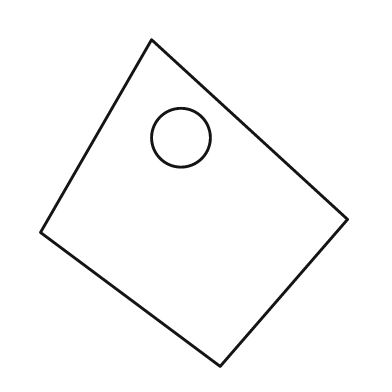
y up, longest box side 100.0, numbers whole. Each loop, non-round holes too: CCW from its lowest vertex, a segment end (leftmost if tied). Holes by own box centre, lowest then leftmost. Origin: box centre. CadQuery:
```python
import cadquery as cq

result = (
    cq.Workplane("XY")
    .moveTo(8.0, -50.0)
    .lineTo(47.0, -5.0)
    .lineTo(-13.0, 50.0)
    .lineTo(-47.0, -9.0)
    .close()
    .moveTo(-4.0, 20.0)
    .circle(9.0)
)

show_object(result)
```